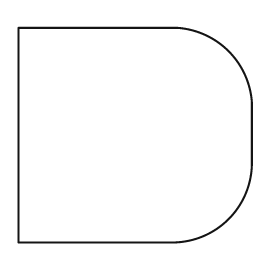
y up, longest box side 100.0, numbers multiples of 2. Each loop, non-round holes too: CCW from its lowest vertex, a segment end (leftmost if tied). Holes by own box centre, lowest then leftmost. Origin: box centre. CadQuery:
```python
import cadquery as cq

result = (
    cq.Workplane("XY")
    .moveTo(-50.0, -46.0)
    .lineTo(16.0, -46.0)
    .threePointArc((40.0, -36.0), (50.0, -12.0))
    .lineTo(50.0, 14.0)
    .threePointArc((40.0, 36.0), (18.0, 46.0))
    .lineTo(-50.0, 46.0)
    .close()
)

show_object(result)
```